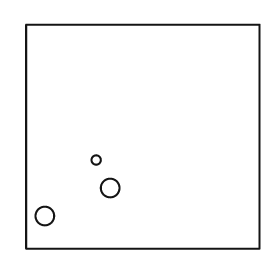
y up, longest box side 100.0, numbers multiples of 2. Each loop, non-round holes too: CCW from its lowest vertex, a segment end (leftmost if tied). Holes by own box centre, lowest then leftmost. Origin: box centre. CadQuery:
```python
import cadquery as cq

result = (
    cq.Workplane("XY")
    .moveTo(-50.0, -48.0)
    .lineTo(50.0, -48.0)
    .lineTo(50.0, 48.0)
    .lineTo(-50.0, 48.0)
    .close()
    .moveTo(-42.0, -34.0)
    .circle(4.0)
    .moveTo(-14.0, -22.0)
    .circle(4.0)
    .moveTo(-20.0, -10.0)
    .circle(2.0)
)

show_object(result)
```